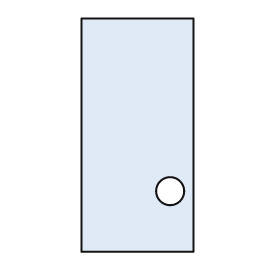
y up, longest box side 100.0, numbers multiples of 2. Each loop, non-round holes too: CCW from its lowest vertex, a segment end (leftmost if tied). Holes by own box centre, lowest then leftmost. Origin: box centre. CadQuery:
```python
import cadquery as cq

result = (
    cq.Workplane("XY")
    .moveTo(-24.0, -50.0)
    .lineTo(24.0, -50.0)
    .lineTo(24.0, 50.0)
    .lineTo(-24.0, 50.0)
    .close()
    .moveTo(14.0, -24.0)
    .circle(6.0)
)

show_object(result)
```